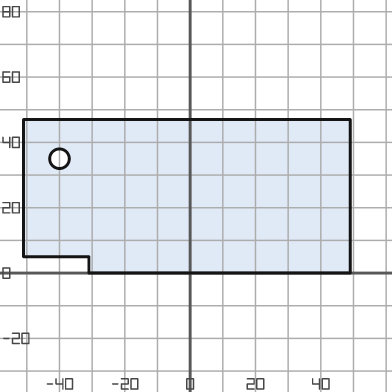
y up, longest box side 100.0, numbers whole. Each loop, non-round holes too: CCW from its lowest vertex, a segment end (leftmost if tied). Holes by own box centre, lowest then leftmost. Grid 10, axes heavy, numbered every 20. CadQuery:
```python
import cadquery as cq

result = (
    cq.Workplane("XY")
    .moveTo(-31.0, 0.0)
    .lineTo(49.0, 0.0)
    .lineTo(49.0, 47.0)
    .lineTo(-51.0, 47.0)
    .lineTo(-51.0, 5.0)
    .lineTo(-31.0, 5.0)
    .close()
    .moveTo(-40.0, 35.0)
    .circle(3.0)
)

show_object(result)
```